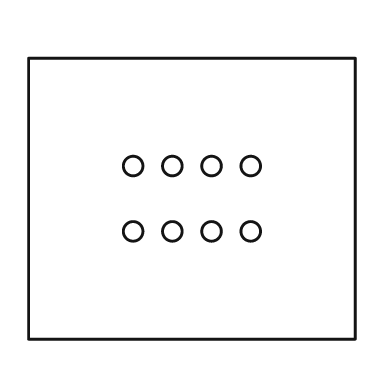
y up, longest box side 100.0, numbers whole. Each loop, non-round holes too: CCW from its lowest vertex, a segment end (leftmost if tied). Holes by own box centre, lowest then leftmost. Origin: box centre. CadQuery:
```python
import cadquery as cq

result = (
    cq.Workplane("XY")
    .moveTo(-50.0, -43.0)
    .lineTo(50.0, -43.0)
    .lineTo(50.0, 43.0)
    .lineTo(-50.0, 43.0)
    .close()
    .moveTo(-18.0, -10.0)
    .circle(3.0)
    .moveTo(-6.0, -10.0)
    .circle(3.0)
    .moveTo(6.0, -10.0)
    .circle(3.0)
    .moveTo(18.0, -10.0)
    .circle(3.0)
    .moveTo(-18.0, 10.0)
    .circle(3.0)
    .moveTo(-6.0, 10.0)
    .circle(3.0)
    .moveTo(6.0, 10.0)
    .circle(3.0)
    .moveTo(18.0, 10.0)
    .circle(3.0)
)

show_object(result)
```